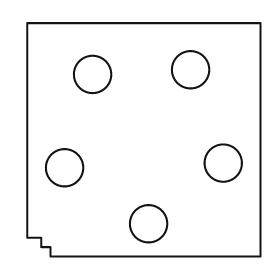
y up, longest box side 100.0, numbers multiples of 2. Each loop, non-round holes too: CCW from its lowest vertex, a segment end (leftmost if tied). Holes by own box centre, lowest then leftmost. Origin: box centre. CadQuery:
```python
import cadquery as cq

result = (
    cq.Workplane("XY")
    .moveTo(-40.0, -50.0)
    .lineTo(50.0, -50.0)
    .lineTo(50.0, 50.0)
    .lineTo(-50.0, 50.0)
    .lineTo(-50.0, -42.0)
    .lineTo(-44.0, -42.0)
    .lineTo(-44.0, -46.0)
    .lineTo(-40.0, -46.0)
    .close()
    .moveTo(2.0, -36.0)
    .circle(8.0)
    .moveTo(-34.0, -12.0)
    .circle(8.0)
    .moveTo(34.0, -10.0)
    .circle(8.0)
    .moveTo(-22.0, 28.0)
    .circle(8.0)
    .moveTo(20.0, 30.0)
    .circle(8.0)
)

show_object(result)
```